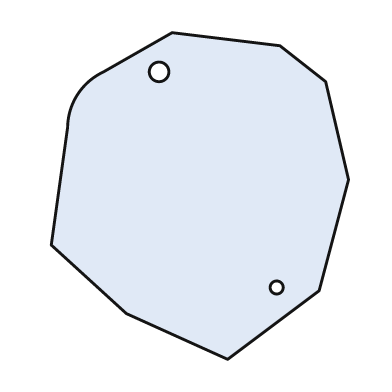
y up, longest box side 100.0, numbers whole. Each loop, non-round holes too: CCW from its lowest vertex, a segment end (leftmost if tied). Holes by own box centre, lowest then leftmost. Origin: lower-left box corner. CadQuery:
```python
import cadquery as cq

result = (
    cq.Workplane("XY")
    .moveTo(54.0, 0.0)
    .lineTo(82.0, 21.0)
    .lineTo(91.0, 55.0)
    .lineTo(84.0, 85.0)
    .lineTo(70.0, 96.0)
    .lineTo(37.0, 100.0)
    .lineTo(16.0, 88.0)
    .threePointArc((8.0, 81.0), (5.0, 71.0))
    .lineTo(0.0, 35.0)
    .lineTo(23.0, 14.0)
    .close()
    .moveTo(69.0, 22.0)
    .circle(2.0)
    .moveTo(33.0, 88.0)
    .circle(3.0)
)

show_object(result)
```